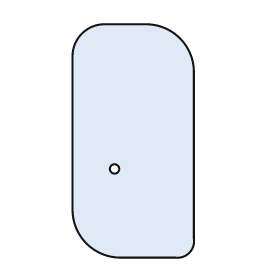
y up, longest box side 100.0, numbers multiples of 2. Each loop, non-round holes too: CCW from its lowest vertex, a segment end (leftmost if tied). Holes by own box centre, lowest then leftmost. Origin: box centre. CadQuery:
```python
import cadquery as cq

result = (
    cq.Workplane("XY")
    .moveTo(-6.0, -50.0)
    .lineTo(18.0, -50.0)
    .threePointArc((24.0, -48.0), (26.0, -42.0))
    .lineTo(26.0, 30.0)
    .threePointArc((20.0, 44.0), (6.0, 50.0))
    .lineTo(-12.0, 50.0)
    .threePointArc((-22.0, 46.0), (-26.0, 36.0))
    .lineTo(-26.0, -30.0)
    .threePointArc((-20.0, -44.0), (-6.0, -50.0))
    .close()
    .moveTo(-8.0, -12.0)
    .circle(2.0)
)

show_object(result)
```